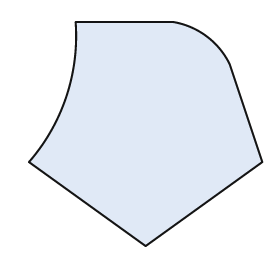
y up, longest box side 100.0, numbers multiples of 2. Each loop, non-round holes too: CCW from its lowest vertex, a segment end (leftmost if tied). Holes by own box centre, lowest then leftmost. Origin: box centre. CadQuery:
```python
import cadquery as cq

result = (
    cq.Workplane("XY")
    .moveTo(0.0, -48.0)
    .lineTo(50.0, -12.0)
    .lineTo(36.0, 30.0)
    .threePointArc((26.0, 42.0), (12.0, 48.0))
    .lineTo(-30.0, 48.0)
    .threePointArc((-34.0, 16.0), (-50.0, -12.0))
    .close()
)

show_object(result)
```